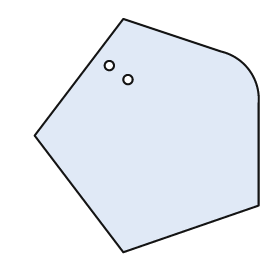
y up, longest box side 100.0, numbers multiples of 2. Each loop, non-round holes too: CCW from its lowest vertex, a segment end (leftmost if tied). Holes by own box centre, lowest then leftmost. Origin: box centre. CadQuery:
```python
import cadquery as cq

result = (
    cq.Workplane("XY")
    .moveTo(-10.0, -50.0)
    .lineTo(48.0, -30.0)
    .lineTo(48.0, 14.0)
    .threePointArc((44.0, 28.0), (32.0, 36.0))
    .lineTo(-10.0, 50.0)
    .lineTo(-48.0, 0.0)
    .close()
    .moveTo(-8.0, 24.0)
    .circle(2.0)
    .moveTo(-16.0, 30.0)
    .circle(2.0)
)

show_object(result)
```